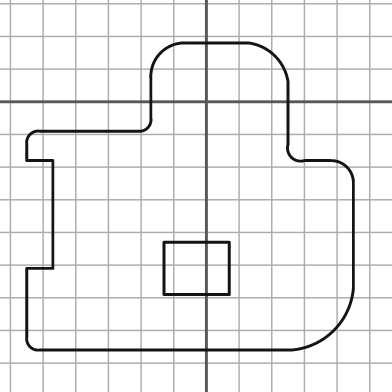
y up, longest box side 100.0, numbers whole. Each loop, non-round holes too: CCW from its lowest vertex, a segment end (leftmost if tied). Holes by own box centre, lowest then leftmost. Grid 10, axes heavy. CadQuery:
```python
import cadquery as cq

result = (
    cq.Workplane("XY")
    .moveTo(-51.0, -76.0)
    .lineTo(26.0, -76.0)
    .threePointArc((39.0, -70.0), (45.0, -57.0))
    .lineTo(45.0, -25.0)
    .threePointArc((43.0, -20.0), (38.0, -18.0))
    .lineTo(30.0, -18.0)
    .threePointArc((26.0, -17.0), (25.0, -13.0))
    .lineTo(25.0, 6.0)
    .threePointArc((21.0, 14.0), (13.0, 18.0))
    .lineTo(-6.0, 18.0)
    .threePointArc((-14.0, 15.0), (-17.0, 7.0))
    .lineTo(-17.0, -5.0)
    .threePointArc((-18.0, -8.0), (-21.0, -9.0))
    .lineTo(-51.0, -9.0)
    .threePointArc((-54.0, -10.0), (-55.0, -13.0))
    .lineTo(-55.0, -18.0)
    .lineTo(-47.0, -18.0)
    .lineTo(-47.0, -51.0)
    .lineTo(-55.0, -51.0)
    .lineTo(-55.0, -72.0)
    .threePointArc((-54.0, -75.0), (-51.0, -76.0))
    .close()
    .moveTo(-13.0, -59.0)
    .lineTo(7.0, -59.0)
    .lineTo(7.0, -43.0)
    .lineTo(-13.0, -43.0)
    .close()
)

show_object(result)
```